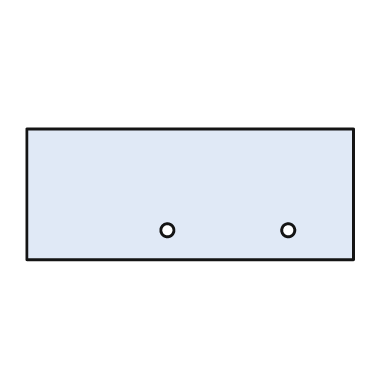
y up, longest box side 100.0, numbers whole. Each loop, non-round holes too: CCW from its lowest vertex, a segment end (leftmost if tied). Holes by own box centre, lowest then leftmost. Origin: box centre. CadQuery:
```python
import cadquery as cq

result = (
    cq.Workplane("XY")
    .moveTo(-50.0, -20.0)
    .lineTo(50.0, -20.0)
    .lineTo(50.0, 20.0)
    .lineTo(-50.0, 20.0)
    .close()
    .moveTo(-7.0, -11.0)
    .circle(2.0)
    .moveTo(30.0, -11.0)
    .circle(2.0)
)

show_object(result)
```